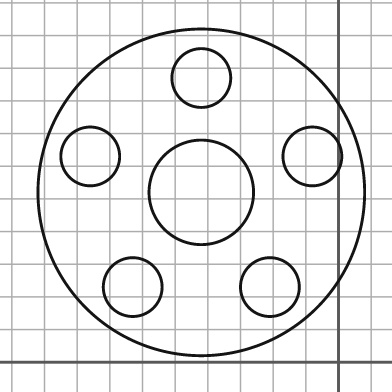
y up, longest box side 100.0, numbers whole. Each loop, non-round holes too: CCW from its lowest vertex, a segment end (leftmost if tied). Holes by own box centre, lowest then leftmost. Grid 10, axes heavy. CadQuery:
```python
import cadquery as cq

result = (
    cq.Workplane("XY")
    .moveTo(-42.0, 52.0)
    .circle(50.0)
    .moveTo(-63.0, 23.0)
    .circle(9.0)
    .moveTo(-21.0, 23.0)
    .circle(9.0)
    .moveTo(-42.0, 52.0)
    .circle(16.0)
    .moveTo(-76.0, 63.0)
    .circle(9.0)
    .moveTo(-8.0, 63.0)
    .circle(9.0)
    .moveTo(-42.0, 87.0)
    .circle(9.0)
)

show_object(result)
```